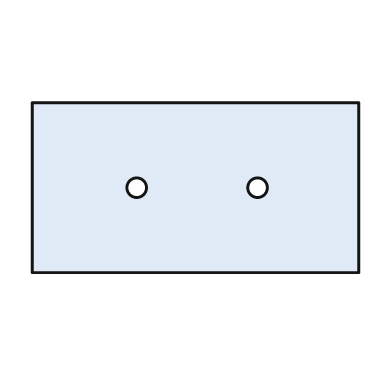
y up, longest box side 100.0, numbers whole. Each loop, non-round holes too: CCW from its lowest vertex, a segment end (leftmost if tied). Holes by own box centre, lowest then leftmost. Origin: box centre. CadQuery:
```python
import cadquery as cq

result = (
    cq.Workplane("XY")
    .moveTo(-50.0, -26.0)
    .lineTo(50.0, -26.0)
    .lineTo(50.0, 26.0)
    .lineTo(-50.0, 26.0)
    .close()
    .moveTo(-18.0, 0.0)
    .circle(3.0)
    .moveTo(19.0, 0.0)
    .circle(3.0)
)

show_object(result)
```